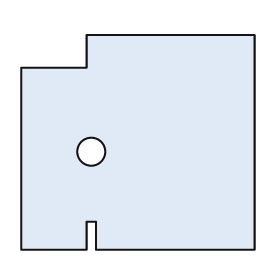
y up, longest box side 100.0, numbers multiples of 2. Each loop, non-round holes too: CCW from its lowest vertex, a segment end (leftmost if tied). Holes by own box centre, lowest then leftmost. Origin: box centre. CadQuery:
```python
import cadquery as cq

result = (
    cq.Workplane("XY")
    .moveTo(-50.0, -46.0)
    .lineTo(-22.0, -46.0)
    .lineTo(-22.0, -34.0)
    .lineTo(-18.0, -34.0)
    .lineTo(-18.0, -46.0)
    .lineTo(50.0, -46.0)
    .lineTo(50.0, 46.0)
    .lineTo(-22.0, 46.0)
    .lineTo(-22.0, 32.0)
    .lineTo(-50.0, 32.0)
    .close()
    .moveTo(-20.0, -4.0)
    .circle(6.0)
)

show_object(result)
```